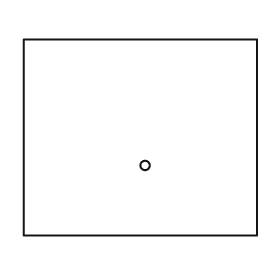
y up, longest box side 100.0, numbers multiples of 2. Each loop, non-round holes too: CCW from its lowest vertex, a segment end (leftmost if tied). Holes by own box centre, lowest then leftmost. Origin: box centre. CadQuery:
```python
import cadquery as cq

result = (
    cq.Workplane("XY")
    .moveTo(-50.0, -42.0)
    .lineTo(50.0, -42.0)
    .lineTo(50.0, 42.0)
    .lineTo(-50.0, 42.0)
    .close()
    .moveTo(2.0, -12.0)
    .circle(2.0)
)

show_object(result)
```